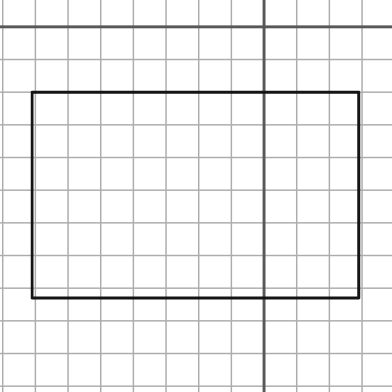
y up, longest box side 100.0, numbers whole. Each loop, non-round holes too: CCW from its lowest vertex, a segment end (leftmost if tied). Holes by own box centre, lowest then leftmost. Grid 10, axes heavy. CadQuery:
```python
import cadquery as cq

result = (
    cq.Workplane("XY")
    .moveTo(-71.0, -83.0)
    .lineTo(29.0, -83.0)
    .lineTo(29.0, -20.0)
    .lineTo(-71.0, -20.0)
    .close()
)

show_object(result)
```